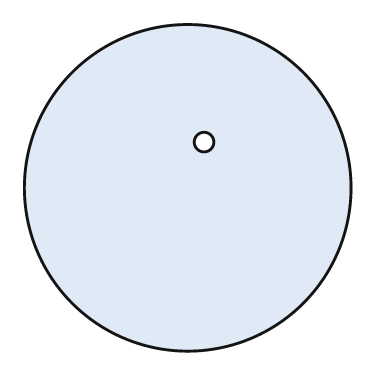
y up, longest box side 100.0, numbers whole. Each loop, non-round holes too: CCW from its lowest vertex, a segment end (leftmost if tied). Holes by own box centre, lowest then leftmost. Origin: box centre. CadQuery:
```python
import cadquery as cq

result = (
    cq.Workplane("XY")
    .moveTo(0.0, 0.0)
    .circle(50.0)
    .moveTo(5.0, 14.0)
    .circle(3.0)
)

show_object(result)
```